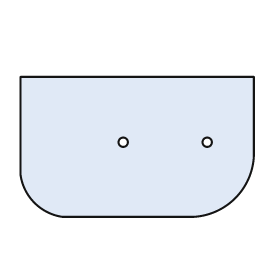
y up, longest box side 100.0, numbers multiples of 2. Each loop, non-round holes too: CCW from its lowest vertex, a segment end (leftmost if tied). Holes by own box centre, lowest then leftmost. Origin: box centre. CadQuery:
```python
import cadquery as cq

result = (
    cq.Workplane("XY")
    .moveTo(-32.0, -30.0)
    .lineTo(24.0, -30.0)
    .threePointArc((42.0, -22.0), (50.0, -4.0))
    .lineTo(50.0, 30.0)
    .lineTo(-50.0, 30.0)
    .lineTo(-50.0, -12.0)
    .threePointArc((-44.0, -24.0), (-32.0, -30.0))
    .close()
    .moveTo(-6.0, 2.0)
    .circle(2.0)
    .moveTo(30.0, 2.0)
    .circle(2.0)
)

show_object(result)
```